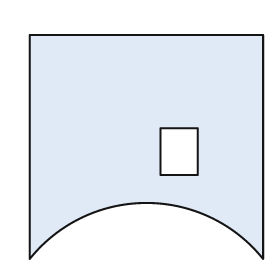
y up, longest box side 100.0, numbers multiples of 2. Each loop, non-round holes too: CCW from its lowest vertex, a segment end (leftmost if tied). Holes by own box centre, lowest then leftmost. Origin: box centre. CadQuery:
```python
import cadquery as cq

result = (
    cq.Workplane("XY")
    .moveTo(-50.0, -48.0)
    .threePointArc((0.0, -24.0), (50.0, -48.0))
    .lineTo(50.0, 48.0)
    .lineTo(-50.0, 48.0)
    .close()
    .moveTo(6.0, -12.0)
    .lineTo(22.0, -12.0)
    .lineTo(22.0, 8.0)
    .lineTo(6.0, 8.0)
    .close()
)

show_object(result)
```